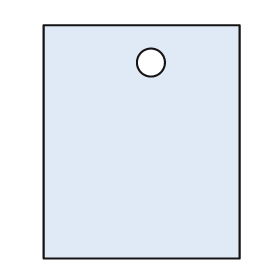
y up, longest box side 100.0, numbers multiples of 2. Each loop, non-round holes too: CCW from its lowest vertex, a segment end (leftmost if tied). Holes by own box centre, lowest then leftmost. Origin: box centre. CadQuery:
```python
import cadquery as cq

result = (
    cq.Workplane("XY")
    .moveTo(-42.0, -50.0)
    .lineTo(42.0, -50.0)
    .lineTo(42.0, 50.0)
    .lineTo(-42.0, 50.0)
    .close()
    .moveTo(4.0, 34.0)
    .circle(6.0)
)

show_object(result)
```